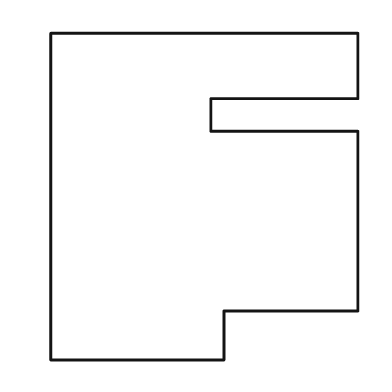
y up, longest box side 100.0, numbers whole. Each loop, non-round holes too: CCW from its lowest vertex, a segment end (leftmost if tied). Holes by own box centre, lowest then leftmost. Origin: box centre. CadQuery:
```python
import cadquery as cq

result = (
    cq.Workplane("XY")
    .moveTo(-47.0, -50.0)
    .lineTo(6.0, -50.0)
    .lineTo(6.0, -35.0)
    .lineTo(47.0, -35.0)
    .lineTo(47.0, 20.0)
    .lineTo(2.0, 20.0)
    .lineTo(2.0, 30.0)
    .lineTo(47.0, 30.0)
    .lineTo(47.0, 50.0)
    .lineTo(-47.0, 50.0)
    .close()
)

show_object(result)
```